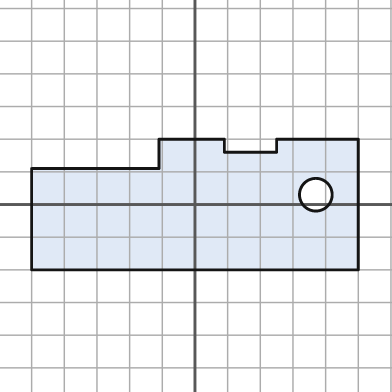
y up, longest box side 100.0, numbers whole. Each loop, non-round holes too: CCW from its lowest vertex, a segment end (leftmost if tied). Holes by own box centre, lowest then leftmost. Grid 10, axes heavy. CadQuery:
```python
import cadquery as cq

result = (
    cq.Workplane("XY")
    .moveTo(-50.0, -20.0)
    .lineTo(50.0, -20.0)
    .lineTo(50.0, 20.0)
    .lineTo(25.0, 20.0)
    .lineTo(25.0, 16.0)
    .lineTo(9.0, 16.0)
    .lineTo(9.0, 20.0)
    .lineTo(-11.0, 20.0)
    .lineTo(-11.0, 11.0)
    .lineTo(-50.0, 11.0)
    .close()
    .moveTo(37.0, 3.0)
    .circle(5.0)
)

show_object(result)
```